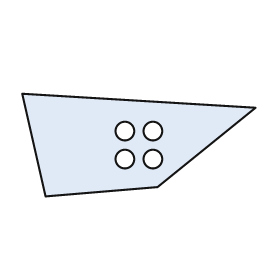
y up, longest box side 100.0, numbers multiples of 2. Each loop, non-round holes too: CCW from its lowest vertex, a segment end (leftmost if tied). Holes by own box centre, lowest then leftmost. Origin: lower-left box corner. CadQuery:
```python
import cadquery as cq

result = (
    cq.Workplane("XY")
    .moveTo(10.0, 0.0)
    .lineTo(58.0, 4.0)
    .lineTo(100.0, 38.0)
    .lineTo(0.0, 44.0)
    .close()
    .moveTo(44.0, 16.0)
    .circle(4.0)
    .moveTo(56.0, 16.0)
    .circle(4.0)
    .moveTo(44.0, 28.0)
    .circle(4.0)
    .moveTo(56.0, 28.0)
    .circle(4.0)
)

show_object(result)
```